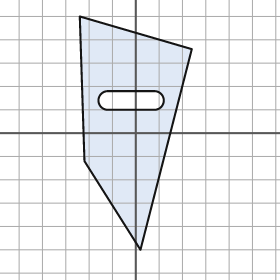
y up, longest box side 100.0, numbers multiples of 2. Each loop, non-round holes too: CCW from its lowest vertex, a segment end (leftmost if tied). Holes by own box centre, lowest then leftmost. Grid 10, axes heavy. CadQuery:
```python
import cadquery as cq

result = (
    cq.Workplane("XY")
    .moveTo(2.0, -50.0)
    .lineTo(24.0, 36.0)
    .lineTo(-24.0, 50.0)
    .lineTo(-22.0, -12.0)
    .close()
    .moveTo(-12.0, 10.0)
    .lineTo(8.0, 10.0)
    .threePointArc((12.0, 14.0), (8.0, 18.0))
    .lineTo(-12.0, 18.0)
    .threePointArc((-16.0, 14.0), (-12.0, 10.0))
    .close()
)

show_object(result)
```